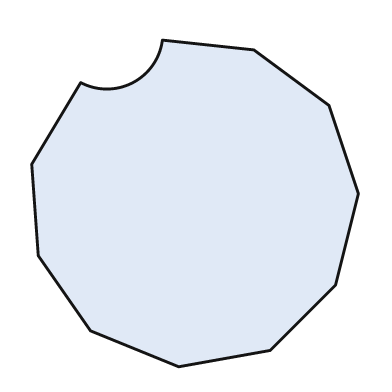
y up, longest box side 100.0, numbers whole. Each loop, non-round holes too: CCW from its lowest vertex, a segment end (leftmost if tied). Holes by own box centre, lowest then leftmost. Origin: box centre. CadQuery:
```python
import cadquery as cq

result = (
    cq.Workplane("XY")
    .moveTo(-5.0, -50.0)
    .lineTo(23.0, -45.0)
    .lineTo(43.0, -25.0)
    .lineTo(50.0, 3.0)
    .lineTo(41.0, 30.0)
    .lineTo(18.0, 47.0)
    .lineTo(-10.0, 50.0)
    .threePointArc((-19.0, 37.0), (-35.0, 37.0))
    .lineTo(-50.0, 12.0)
    .lineTo(-48.0, -16.0)
    .lineTo(-32.0, -39.0)
    .close()
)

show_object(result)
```